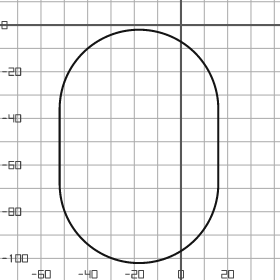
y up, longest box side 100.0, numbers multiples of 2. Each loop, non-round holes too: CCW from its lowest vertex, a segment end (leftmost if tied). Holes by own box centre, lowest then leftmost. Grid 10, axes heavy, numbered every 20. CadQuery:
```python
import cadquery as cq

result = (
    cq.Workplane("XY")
    .moveTo(-52.0, -68.0)
    .threePointArc((-18.0, -102.0), (16.0, -68.0))
    .lineTo(16.0, -36.0)
    .threePointArc((-18.0, -2.0), (-52.0, -36.0))
    .close()
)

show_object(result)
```